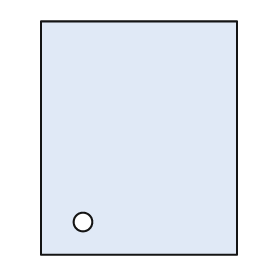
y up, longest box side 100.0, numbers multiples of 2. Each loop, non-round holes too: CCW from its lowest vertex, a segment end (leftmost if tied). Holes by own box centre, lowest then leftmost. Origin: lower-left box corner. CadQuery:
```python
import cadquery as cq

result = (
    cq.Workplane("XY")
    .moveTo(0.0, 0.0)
    .lineTo(84.0, 0.0)
    .lineTo(84.0, 100.0)
    .lineTo(0.0, 100.0)
    .close()
    .moveTo(18.0, 14.0)
    .circle(4.0)
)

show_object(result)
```